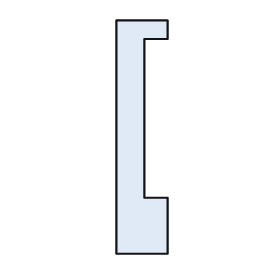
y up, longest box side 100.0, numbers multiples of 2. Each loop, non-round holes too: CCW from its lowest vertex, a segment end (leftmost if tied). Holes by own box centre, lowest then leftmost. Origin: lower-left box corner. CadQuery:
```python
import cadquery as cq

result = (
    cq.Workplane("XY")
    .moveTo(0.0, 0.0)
    .lineTo(22.0, 0.0)
    .lineTo(22.0, 24.0)
    .lineTo(12.0, 24.0)
    .lineTo(12.0, 92.0)
    .lineTo(22.0, 92.0)
    .lineTo(22.0, 100.0)
    .lineTo(0.0, 100.0)
    .close()
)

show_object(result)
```